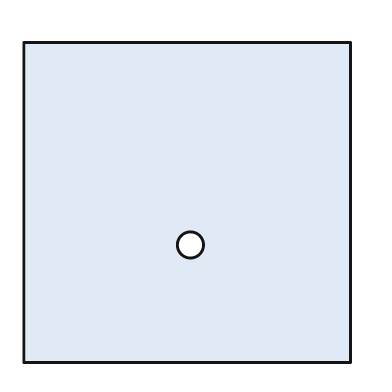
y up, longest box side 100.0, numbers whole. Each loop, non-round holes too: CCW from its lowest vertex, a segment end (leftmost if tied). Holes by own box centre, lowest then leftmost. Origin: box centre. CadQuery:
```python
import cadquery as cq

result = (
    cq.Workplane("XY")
    .moveTo(-50.0, -49.0)
    .lineTo(50.0, -49.0)
    .lineTo(50.0, 49.0)
    .lineTo(-50.0, 49.0)
    .close()
    .moveTo(1.0, -13.0)
    .circle(4.0)
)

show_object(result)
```